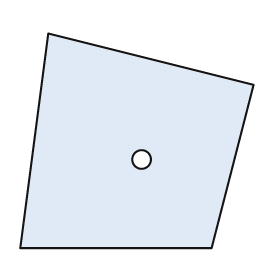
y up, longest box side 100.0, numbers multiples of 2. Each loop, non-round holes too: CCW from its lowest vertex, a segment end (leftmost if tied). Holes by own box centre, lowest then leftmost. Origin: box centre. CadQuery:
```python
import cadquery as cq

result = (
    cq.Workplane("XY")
    .moveTo(-50.0, -46.0)
    .lineTo(32.0, -46.0)
    .lineTo(50.0, 24.0)
    .lineTo(-38.0, 46.0)
    .close()
    .moveTo(2.0, -8.0)
    .circle(4.0)
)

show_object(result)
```